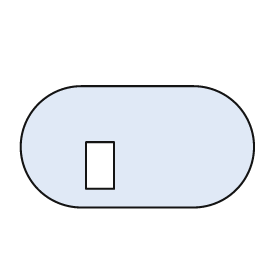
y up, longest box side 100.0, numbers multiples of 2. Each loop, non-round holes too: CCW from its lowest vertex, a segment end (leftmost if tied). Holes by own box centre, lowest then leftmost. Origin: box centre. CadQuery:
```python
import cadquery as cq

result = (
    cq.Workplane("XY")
    .moveTo(-24.0, -26.0)
    .lineTo(24.0, -26.0)
    .threePointArc((50.0, 0.0), (24.0, 26.0))
    .lineTo(-24.0, 26.0)
    .threePointArc((-50.0, 0.0), (-24.0, -26.0))
    .close()
    .moveTo(-22.0, -18.0)
    .lineTo(-10.0, -18.0)
    .lineTo(-10.0, 2.0)
    .lineTo(-22.0, 2.0)
    .close()
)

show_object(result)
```